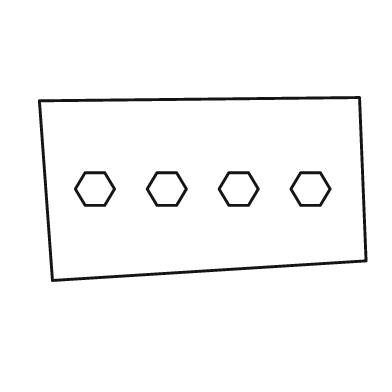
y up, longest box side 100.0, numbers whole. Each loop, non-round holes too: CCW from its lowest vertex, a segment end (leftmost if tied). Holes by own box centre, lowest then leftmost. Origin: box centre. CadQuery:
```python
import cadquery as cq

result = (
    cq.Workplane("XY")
    .moveTo(-46.0, -28.0)
    .lineTo(50.0, -22.0)
    .lineTo(48.0, 28.0)
    .lineTo(-50.0, 27.0)
    .close()
    .moveTo(-36.0, -5.0)
    .lineTo(-30.0, -5.0)
    .lineTo(-27.0, 0.0)
    .lineTo(-30.0, 5.0)
    .lineTo(-36.0, 5.0)
    .lineTo(-39.0, 0.0)
    .close()
    .moveTo(-14.0, -5.0)
    .lineTo(-8.0, -5.0)
    .lineTo(-5.0, 0.0)
    .lineTo(-8.0, 5.0)
    .lineTo(-14.0, 5.0)
    .lineTo(-17.0, 0.0)
    .close()
    .moveTo(8.0, -5.0)
    .lineTo(14.0, -5.0)
    .lineTo(17.0, 0.0)
    .lineTo(14.0, 5.0)
    .lineTo(8.0, 5.0)
    .lineTo(5.0, 0.0)
    .close()
    .moveTo(30.0, -5.0)
    .lineTo(36.0, -5.0)
    .lineTo(39.0, 0.0)
    .lineTo(36.0, 5.0)
    .lineTo(30.0, 5.0)
    .lineTo(27.0, 0.0)
    .close()
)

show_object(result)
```